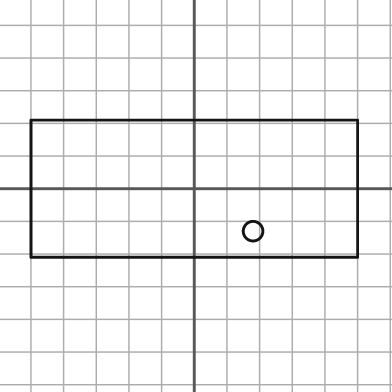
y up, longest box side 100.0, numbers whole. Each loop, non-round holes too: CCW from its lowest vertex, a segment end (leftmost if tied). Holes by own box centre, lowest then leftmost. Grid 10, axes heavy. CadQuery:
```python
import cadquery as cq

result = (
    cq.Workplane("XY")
    .moveTo(-50.0, -21.0)
    .lineTo(50.0, -21.0)
    .lineTo(50.0, 21.0)
    .lineTo(-50.0, 21.0)
    .close()
    .moveTo(18.0, -13.0)
    .circle(3.0)
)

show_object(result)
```